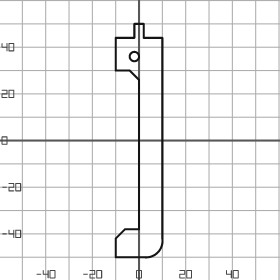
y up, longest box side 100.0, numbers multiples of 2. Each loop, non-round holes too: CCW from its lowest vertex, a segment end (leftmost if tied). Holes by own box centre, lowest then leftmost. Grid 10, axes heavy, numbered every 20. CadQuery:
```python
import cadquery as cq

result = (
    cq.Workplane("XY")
    .moveTo(-10.0, -50.0)
    .lineTo(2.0, -50.0)
    .threePointArc((8.0, -48.0), (10.0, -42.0))
    .lineTo(10.0, 44.0)
    .lineTo(2.0, 44.0)
    .lineTo(2.0, 50.0)
    .lineTo(-2.0, 50.0)
    .lineTo(-2.0, 44.0)
    .lineTo(-10.0, 44.0)
    .lineTo(-10.0, 30.0)
    .lineTo(-4.0, 30.0)
    .lineTo(0.0, 26.0)
    .lineTo(0.0, -38.0)
    .lineTo(-6.0, -38.0)
    .lineTo(-10.0, -42.0)
    .close()
    .moveTo(-2.0, 36.0)
    .circle(2.0)
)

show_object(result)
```